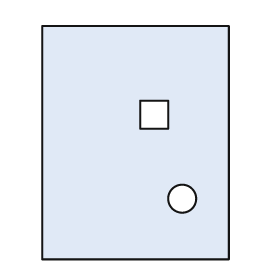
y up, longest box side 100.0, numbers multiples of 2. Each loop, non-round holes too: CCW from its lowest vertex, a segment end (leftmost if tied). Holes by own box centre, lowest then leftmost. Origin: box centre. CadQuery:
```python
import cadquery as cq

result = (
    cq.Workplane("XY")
    .moveTo(-40.0, -50.0)
    .lineTo(40.0, -50.0)
    .lineTo(40.0, 50.0)
    .lineTo(-40.0, 50.0)
    .close()
    .moveTo(20.0, -24.0)
    .circle(6.0)
    .moveTo(2.0, 6.0)
    .lineTo(14.0, 6.0)
    .lineTo(14.0, 18.0)
    .lineTo(2.0, 18.0)
    .close()
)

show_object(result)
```